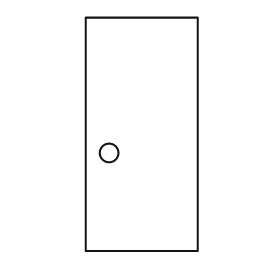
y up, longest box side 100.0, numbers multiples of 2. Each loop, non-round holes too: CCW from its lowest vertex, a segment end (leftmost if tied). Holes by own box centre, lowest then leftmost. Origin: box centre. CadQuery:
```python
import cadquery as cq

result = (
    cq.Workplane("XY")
    .moveTo(-24.0, -50.0)
    .lineTo(24.0, -50.0)
    .lineTo(24.0, 50.0)
    .lineTo(-24.0, 50.0)
    .close()
    .moveTo(-14.0, -8.0)
    .circle(4.0)
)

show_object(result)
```